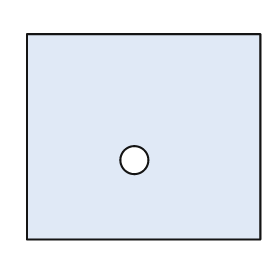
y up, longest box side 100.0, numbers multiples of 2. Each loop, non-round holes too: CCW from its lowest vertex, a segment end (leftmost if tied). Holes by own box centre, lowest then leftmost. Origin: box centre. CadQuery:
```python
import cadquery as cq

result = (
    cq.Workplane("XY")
    .moveTo(-50.0, -44.0)
    .lineTo(50.0, -44.0)
    .lineTo(50.0, 44.0)
    .lineTo(-50.0, 44.0)
    .close()
    .moveTo(-4.0, -10.0)
    .circle(6.0)
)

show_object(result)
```